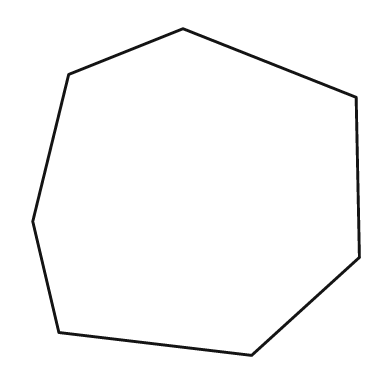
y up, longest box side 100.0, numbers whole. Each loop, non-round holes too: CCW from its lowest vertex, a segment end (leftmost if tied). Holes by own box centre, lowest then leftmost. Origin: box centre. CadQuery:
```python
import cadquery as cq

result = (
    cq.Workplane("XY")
    .moveTo(17.0, -50.0)
    .lineTo(50.0, -20.0)
    .lineTo(49.0, 29.0)
    .lineTo(-4.0, 50.0)
    .lineTo(-39.0, 36.0)
    .lineTo(-50.0, -9.0)
    .lineTo(-42.0, -43.0)
    .close()
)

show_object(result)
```